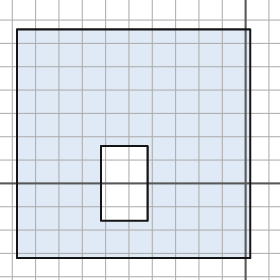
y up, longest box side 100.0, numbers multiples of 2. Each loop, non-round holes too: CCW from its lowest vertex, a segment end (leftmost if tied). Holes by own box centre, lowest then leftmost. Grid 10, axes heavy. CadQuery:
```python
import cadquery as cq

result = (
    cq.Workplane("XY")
    .moveTo(-98.0, -32.0)
    .lineTo(2.0, -32.0)
    .lineTo(2.0, 66.0)
    .lineTo(-98.0, 66.0)
    .close()
    .moveTo(-62.0, -16.0)
    .lineTo(-42.0, -16.0)
    .lineTo(-42.0, 16.0)
    .lineTo(-62.0, 16.0)
    .close()
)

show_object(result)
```